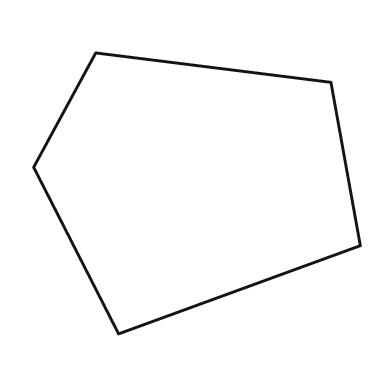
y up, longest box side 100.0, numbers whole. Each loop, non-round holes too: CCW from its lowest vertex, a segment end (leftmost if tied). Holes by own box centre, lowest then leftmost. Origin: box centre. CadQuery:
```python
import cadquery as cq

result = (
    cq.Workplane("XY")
    .moveTo(-24.0, -43.0)
    .lineTo(50.0, -16.0)
    .lineTo(41.0, 34.0)
    .lineTo(-31.0, 43.0)
    .lineTo(-50.0, 8.0)
    .close()
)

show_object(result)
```